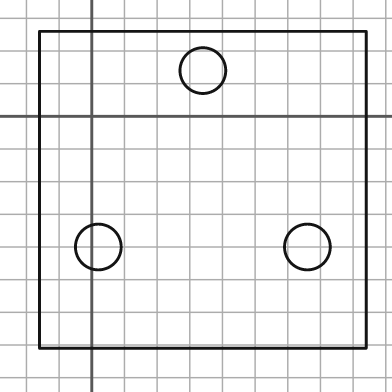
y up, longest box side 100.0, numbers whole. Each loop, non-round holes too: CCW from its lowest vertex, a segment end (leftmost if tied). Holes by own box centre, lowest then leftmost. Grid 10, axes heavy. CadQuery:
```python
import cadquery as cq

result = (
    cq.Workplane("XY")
    .moveTo(-16.0, -71.0)
    .lineTo(84.0, -71.0)
    .lineTo(84.0, 26.0)
    .lineTo(-16.0, 26.0)
    .close()
    .moveTo(2.0, -40.0)
    .circle(7.0)
    .moveTo(66.0, -40.0)
    .circle(7.0)
    .moveTo(34.0, 14.0)
    .circle(7.0)
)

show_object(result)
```